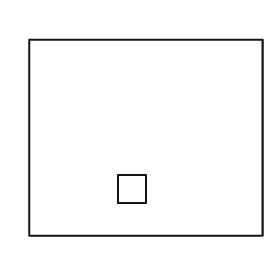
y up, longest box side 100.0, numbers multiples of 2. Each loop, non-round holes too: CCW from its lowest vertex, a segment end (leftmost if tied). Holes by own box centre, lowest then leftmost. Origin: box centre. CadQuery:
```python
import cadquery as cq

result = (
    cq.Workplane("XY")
    .moveTo(-50.0, -42.0)
    .lineTo(50.0, -42.0)
    .lineTo(50.0, 42.0)
    .lineTo(-50.0, 42.0)
    .close()
    .moveTo(-12.0, -28.0)
    .lineTo(0.0, -28.0)
    .lineTo(0.0, -16.0)
    .lineTo(-12.0, -16.0)
    .close()
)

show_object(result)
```